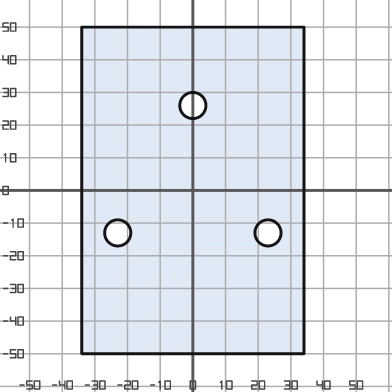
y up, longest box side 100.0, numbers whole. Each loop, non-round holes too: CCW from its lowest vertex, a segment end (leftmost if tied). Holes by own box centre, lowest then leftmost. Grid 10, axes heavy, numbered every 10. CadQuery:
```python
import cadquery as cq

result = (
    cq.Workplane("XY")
    .moveTo(-34.0, -50.0)
    .lineTo(34.0, -50.0)
    .lineTo(34.0, 50.0)
    .lineTo(-34.0, 50.0)
    .close()
    .moveTo(-23.0, -13.0)
    .circle(4.0)
    .moveTo(23.0, -13.0)
    .circle(4.0)
    .moveTo(0.0, 26.0)
    .circle(4.0)
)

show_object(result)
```